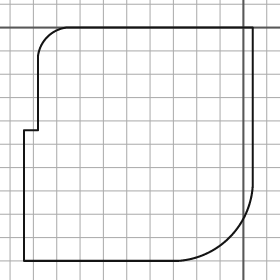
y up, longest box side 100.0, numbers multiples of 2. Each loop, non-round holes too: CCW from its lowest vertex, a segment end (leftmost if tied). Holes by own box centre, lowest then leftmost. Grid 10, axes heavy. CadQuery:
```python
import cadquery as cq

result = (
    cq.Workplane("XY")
    .moveTo(-94.0, -100.0)
    .lineTo(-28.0, -100.0)
    .threePointArc((-6.0, -90.0), (4.0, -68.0))
    .lineTo(4.0, 0.0)
    .lineTo(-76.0, 0.0)
    .threePointArc((-84.0, -4.0), (-88.0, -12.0))
    .lineTo(-88.0, -44.0)
    .lineTo(-94.0, -44.0)
    .close()
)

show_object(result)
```